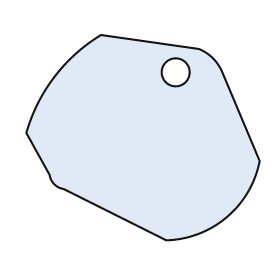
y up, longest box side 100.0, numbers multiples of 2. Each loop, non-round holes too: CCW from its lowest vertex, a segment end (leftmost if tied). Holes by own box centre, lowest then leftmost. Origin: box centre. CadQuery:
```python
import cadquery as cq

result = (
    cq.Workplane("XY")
    .moveTo(10.0, -44.0)
    .threePointArc((36.0, -34.0), (50.0, -10.0))
    .lineTo(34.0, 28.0)
    .threePointArc((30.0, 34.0), (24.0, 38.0))
    .lineTo(-18.0, 44.0)
    .threePointArc((-38.0, 26.0), (-50.0, 2.0))
    .lineTo(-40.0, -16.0)
    .threePointArc((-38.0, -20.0), (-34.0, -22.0))
    .close()
    .moveTo(14.0, 28.0)
    .circle(6.0)
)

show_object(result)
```